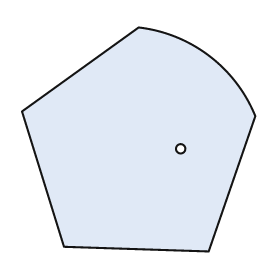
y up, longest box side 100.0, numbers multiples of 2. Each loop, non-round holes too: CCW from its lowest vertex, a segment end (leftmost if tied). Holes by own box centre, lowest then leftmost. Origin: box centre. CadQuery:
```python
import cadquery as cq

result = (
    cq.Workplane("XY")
    .moveTo(30.0, -48.0)
    .lineTo(50.0, 10.0)
    .threePointArc((30.0, 36.0), (0.0, 48.0))
    .lineTo(-50.0, 12.0)
    .lineTo(-32.0, -46.0)
    .close()
    .moveTo(18.0, -4.0)
    .circle(2.0)
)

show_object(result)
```